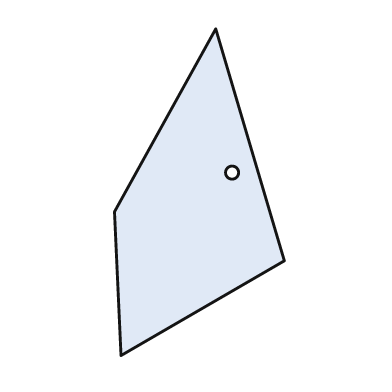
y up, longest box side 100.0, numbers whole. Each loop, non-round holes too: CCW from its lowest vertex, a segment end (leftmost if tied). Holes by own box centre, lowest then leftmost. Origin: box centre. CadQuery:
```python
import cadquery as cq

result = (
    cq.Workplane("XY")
    .moveTo(-24.0, -50.0)
    .lineTo(26.0, -21.0)
    .lineTo(5.0, 50.0)
    .lineTo(-26.0, -6.0)
    .close()
    .moveTo(10.0, 6.0)
    .circle(2.0)
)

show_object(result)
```